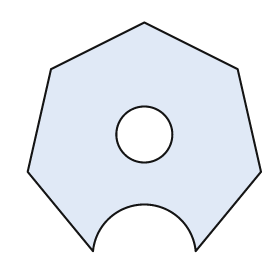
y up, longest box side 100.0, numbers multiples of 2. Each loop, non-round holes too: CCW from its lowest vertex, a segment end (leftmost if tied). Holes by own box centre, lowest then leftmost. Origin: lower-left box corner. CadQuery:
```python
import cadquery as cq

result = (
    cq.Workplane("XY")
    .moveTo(28.0, 0.0)
    .threePointArc((50.0, 20.0), (72.0, 0.0))
    .lineTo(100.0, 34.0)
    .lineTo(90.0, 78.0)
    .lineTo(50.0, 98.0)
    .lineTo(10.0, 78.0)
    .lineTo(0.0, 34.0)
    .close()
    .moveTo(50.0, 50.0)
    .circle(12.0)
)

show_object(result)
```